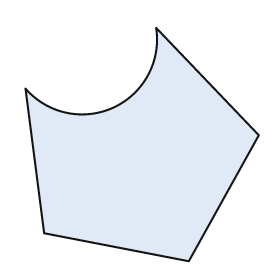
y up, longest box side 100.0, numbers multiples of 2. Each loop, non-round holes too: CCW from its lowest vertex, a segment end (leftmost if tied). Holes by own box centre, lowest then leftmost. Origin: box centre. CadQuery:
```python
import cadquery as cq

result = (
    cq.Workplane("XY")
    .moveTo(20.0, -50.0)
    .lineTo(50.0, 4.0)
    .lineTo(6.0, 50.0)
    .threePointArc((-12.0, 16.0), (-50.0, 24.0))
    .lineTo(-42.0, -38.0)
    .close()
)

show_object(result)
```